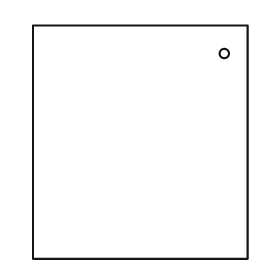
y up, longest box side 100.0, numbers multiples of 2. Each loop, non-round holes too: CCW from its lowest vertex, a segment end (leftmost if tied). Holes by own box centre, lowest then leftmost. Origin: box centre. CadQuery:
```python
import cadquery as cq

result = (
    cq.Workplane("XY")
    .moveTo(-46.0, -50.0)
    .lineTo(46.0, -50.0)
    .lineTo(46.0, 50.0)
    .lineTo(-46.0, 50.0)
    .close()
    .moveTo(36.0, 38.0)
    .circle(2.0)
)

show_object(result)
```